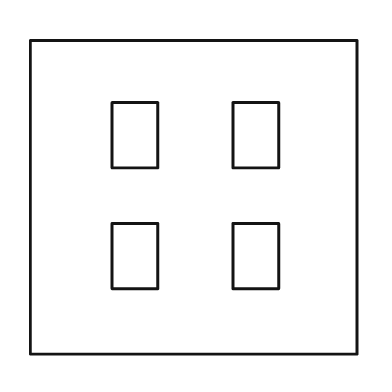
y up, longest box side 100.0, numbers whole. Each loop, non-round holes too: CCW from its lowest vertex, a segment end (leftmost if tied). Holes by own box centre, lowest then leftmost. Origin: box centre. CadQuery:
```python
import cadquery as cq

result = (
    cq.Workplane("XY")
    .moveTo(-50.0, -48.0)
    .lineTo(50.0, -48.0)
    .lineTo(50.0, 48.0)
    .lineTo(-50.0, 48.0)
    .close()
    .moveTo(-25.0, -28.0)
    .lineTo(-11.0, -28.0)
    .lineTo(-11.0, -8.0)
    .lineTo(-25.0, -8.0)
    .close()
    .moveTo(12.0, -28.0)
    .lineTo(26.0, -28.0)
    .lineTo(26.0, -8.0)
    .lineTo(12.0, -8.0)
    .close()
    .moveTo(-25.0, 9.0)
    .lineTo(-11.0, 9.0)
    .lineTo(-11.0, 29.0)
    .lineTo(-25.0, 29.0)
    .close()
    .moveTo(12.0, 9.0)
    .lineTo(26.0, 9.0)
    .lineTo(26.0, 29.0)
    .lineTo(12.0, 29.0)
    .close()
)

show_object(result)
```